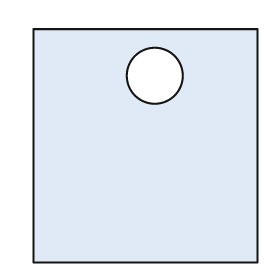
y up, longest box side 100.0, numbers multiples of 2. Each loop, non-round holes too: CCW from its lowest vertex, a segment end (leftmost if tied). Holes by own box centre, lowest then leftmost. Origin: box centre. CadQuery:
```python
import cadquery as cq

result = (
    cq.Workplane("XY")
    .moveTo(-48.0, -50.0)
    .lineTo(48.0, -50.0)
    .lineTo(48.0, 50.0)
    .lineTo(-48.0, 50.0)
    .close()
    .moveTo(4.0, 30.0)
    .circle(12.0)
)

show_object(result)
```